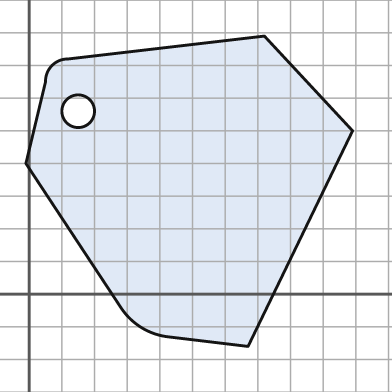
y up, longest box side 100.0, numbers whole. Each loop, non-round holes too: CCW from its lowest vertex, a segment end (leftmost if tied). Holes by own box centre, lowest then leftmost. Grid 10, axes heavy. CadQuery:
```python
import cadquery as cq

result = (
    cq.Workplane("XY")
    .moveTo(67.0, -16.0)
    .lineTo(99.0, 50.0)
    .lineTo(72.0, 79.0)
    .lineTo(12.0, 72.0)
    .threePointArc((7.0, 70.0), (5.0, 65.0))
    .lineTo(-1.0, 40.0)
    .lineTo(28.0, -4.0)
    .threePointArc((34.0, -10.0), (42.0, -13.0))
    .close()
    .moveTo(15.0, 56.0)
    .circle(5.0)
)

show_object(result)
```